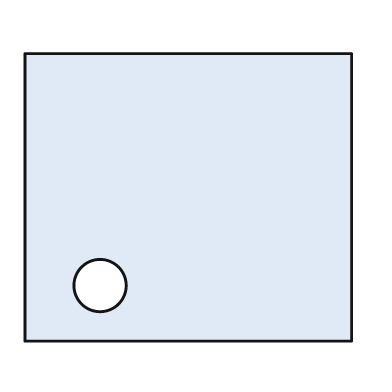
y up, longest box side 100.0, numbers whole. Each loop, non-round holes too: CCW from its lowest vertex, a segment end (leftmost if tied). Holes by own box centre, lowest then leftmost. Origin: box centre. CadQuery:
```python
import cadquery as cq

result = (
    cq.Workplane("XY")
    .moveTo(-50.0, -44.0)
    .lineTo(50.0, -44.0)
    .lineTo(50.0, 44.0)
    .lineTo(-50.0, 44.0)
    .close()
    .moveTo(-27.0, -27.0)
    .circle(8.0)
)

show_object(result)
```